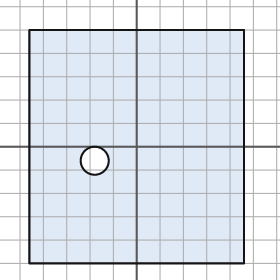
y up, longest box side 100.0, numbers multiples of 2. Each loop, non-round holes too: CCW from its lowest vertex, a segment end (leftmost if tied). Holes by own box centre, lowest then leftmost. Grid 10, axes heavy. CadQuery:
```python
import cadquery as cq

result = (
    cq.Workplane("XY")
    .moveTo(-46.0, -50.0)
    .lineTo(46.0, -50.0)
    .lineTo(46.0, 50.0)
    .lineTo(-46.0, 50.0)
    .close()
    .moveTo(-18.0, -6.0)
    .circle(6.0)
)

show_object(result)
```